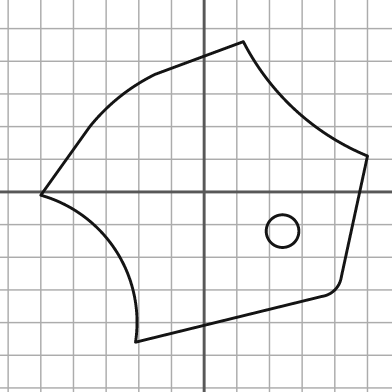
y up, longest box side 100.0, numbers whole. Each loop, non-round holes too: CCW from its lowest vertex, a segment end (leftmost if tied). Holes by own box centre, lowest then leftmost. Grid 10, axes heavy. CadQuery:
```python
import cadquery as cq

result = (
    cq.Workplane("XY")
    .moveTo(-21.0, -46.0)
    .lineTo(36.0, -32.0)
    .threePointArc((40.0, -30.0), (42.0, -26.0))
    .lineTo(50.0, 11.0)
    .threePointArc((28.0, 25.0), (12.0, 46.0))
    .lineTo(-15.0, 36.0)
    .threePointArc((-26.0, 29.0), (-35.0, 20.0))
    .lineTo(-50.0, -1.0)
    .threePointArc((-27.0, -18.0), (-21.0, -46.0))
    .close()
    .moveTo(24.0, -12.0)
    .circle(5.0)
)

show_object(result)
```